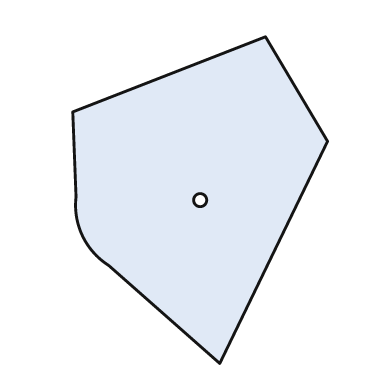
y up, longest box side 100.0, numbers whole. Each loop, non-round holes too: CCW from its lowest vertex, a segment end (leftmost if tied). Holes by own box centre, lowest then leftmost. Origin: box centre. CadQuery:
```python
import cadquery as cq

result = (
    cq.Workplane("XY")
    .moveTo(6.0, -50.0)
    .lineTo(39.0, 18.0)
    .lineTo(20.0, 50.0)
    .lineTo(-39.0, 27.0)
    .lineTo(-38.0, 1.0)
    .threePointArc((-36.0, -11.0), (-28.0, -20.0))
    .close()
    .moveTo(0.0, 0.0)
    .circle(2.0)
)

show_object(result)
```